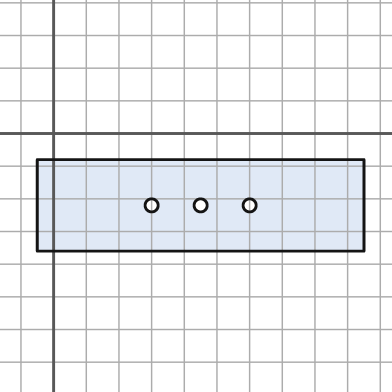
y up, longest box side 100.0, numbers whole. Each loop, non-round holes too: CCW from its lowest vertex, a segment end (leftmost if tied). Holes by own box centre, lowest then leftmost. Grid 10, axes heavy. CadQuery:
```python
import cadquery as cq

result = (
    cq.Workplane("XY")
    .moveTo(-5.0, -36.0)
    .lineTo(95.0, -36.0)
    .lineTo(95.0, -8.0)
    .lineTo(-5.0, -8.0)
    .close()
    .moveTo(30.0, -22.0)
    .circle(2.0)
    .moveTo(45.0, -22.0)
    .circle(2.0)
    .moveTo(60.0, -22.0)
    .circle(2.0)
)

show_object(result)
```